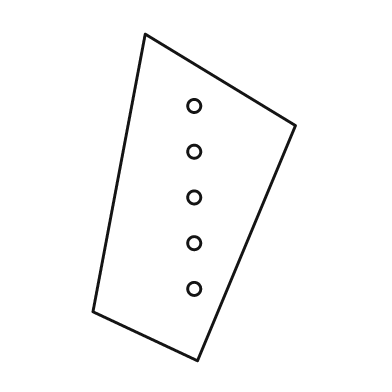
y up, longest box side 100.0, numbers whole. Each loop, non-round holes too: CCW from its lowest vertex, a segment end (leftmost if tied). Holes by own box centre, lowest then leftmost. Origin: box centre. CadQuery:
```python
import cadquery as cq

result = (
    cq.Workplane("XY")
    .moveTo(1.0, -50.0)
    .lineTo(31.0, 22.0)
    .lineTo(-15.0, 50.0)
    .lineTo(-31.0, -35.0)
    .close()
    .moveTo(0.0, -28.0)
    .circle(2.0)
    .moveTo(0.0, -14.0)
    .circle(2.0)
    .moveTo(0.0, 0.0)
    .circle(2.0)
    .moveTo(0.0, 14.0)
    .circle(2.0)
    .moveTo(0.0, 28.0)
    .circle(2.0)
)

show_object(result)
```